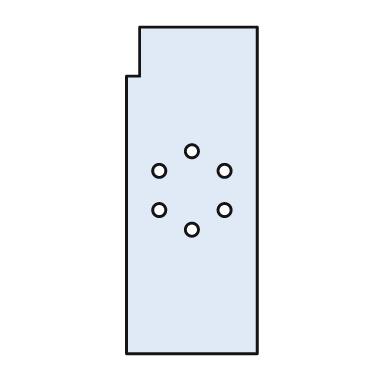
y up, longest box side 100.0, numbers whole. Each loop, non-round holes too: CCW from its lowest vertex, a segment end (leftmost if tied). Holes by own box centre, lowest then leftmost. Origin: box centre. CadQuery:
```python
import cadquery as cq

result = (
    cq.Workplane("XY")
    .moveTo(-20.0, -50.0)
    .lineTo(20.0, -50.0)
    .lineTo(20.0, 50.0)
    .lineTo(-16.0, 50.0)
    .lineTo(-16.0, 35.0)
    .lineTo(-20.0, 35.0)
    .close()
    .moveTo(0.0, -12.0)
    .circle(2.0)
    .moveTo(-10.0, -6.0)
    .circle(2.0)
    .moveTo(10.0, -6.0)
    .circle(2.0)
    .moveTo(-10.0, 6.0)
    .circle(2.0)
    .moveTo(10.0, 6.0)
    .circle(2.0)
    .moveTo(0.0, 12.0)
    .circle(2.0)
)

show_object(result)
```